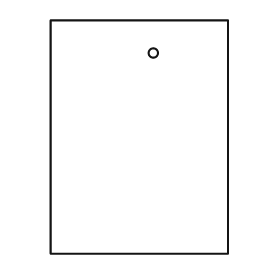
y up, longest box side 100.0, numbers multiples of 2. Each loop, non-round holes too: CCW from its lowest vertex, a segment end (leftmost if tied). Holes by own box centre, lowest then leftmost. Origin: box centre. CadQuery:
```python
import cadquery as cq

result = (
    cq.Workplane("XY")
    .moveTo(-38.0, -50.0)
    .lineTo(38.0, -50.0)
    .lineTo(38.0, 50.0)
    .lineTo(-38.0, 50.0)
    .close()
    .moveTo(6.0, 36.0)
    .circle(2.0)
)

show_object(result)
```